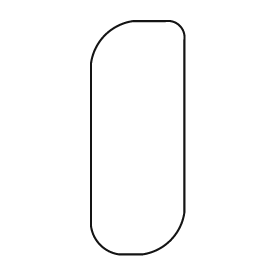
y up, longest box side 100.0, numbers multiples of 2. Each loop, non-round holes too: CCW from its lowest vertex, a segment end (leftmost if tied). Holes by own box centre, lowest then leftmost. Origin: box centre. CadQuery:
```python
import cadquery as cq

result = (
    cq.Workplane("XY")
    .moveTo(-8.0, -50.0)
    .lineTo(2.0, -50.0)
    .threePointArc((14.0, -44.0), (20.0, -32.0))
    .lineTo(20.0, 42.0)
    .threePointArc((18.0, 48.0), (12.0, 50.0))
    .lineTo(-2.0, 50.0)
    .threePointArc((-14.0, 44.0), (-20.0, 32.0))
    .lineTo(-20.0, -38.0)
    .threePointArc((-16.0, -46.0), (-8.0, -50.0))
    .close()
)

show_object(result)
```